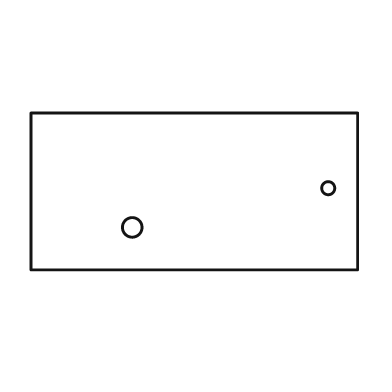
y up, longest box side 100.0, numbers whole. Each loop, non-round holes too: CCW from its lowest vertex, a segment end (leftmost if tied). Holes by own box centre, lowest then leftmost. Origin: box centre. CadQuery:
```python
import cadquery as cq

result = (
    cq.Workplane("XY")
    .moveTo(-50.0, -24.0)
    .lineTo(50.0, -24.0)
    .lineTo(50.0, 24.0)
    .lineTo(-50.0, 24.0)
    .close()
    .moveTo(-19.0, -11.0)
    .circle(3.0)
    .moveTo(41.0, 1.0)
    .circle(2.0)
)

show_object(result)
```